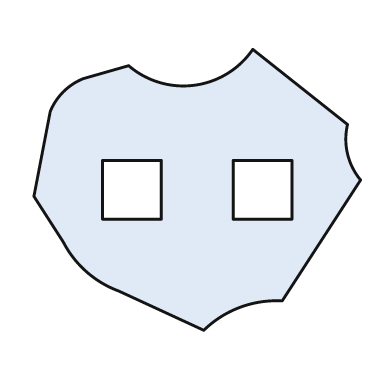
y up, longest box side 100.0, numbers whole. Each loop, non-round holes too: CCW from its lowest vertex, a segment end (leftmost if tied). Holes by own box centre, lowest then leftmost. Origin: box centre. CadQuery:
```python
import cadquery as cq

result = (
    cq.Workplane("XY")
    .moveTo(2.0, -43.0)
    .threePointArc((13.0, -36.0), (26.0, -34.0))
    .lineTo(50.0, 3.0)
    .threePointArc((46.0, 11.0), (46.0, 20.0))
    .lineTo(17.0, 43.0)
    .threePointArc((-1.0, 32.0), (-21.0, 38.0))
    .lineTo(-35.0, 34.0)
    .threePointArc((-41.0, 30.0), (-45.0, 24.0))
    .lineTo(-50.0, -2.0)
    .lineTo(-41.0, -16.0)
    .threePointArc((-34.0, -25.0), (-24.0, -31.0))
    .close()
    .moveTo(-29.0, -9.0)
    .lineTo(-11.0, -9.0)
    .lineTo(-11.0, 9.0)
    .lineTo(-29.0, 9.0)
    .close()
    .moveTo(11.0, -9.0)
    .lineTo(29.0, -9.0)
    .lineTo(29.0, 9.0)
    .lineTo(11.0, 9.0)
    .close()
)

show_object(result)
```